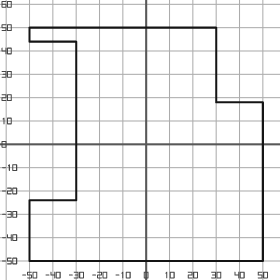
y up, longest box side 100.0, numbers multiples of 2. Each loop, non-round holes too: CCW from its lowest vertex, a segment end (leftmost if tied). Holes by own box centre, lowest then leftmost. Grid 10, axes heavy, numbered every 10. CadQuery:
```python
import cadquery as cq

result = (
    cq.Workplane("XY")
    .moveTo(-50.0, -50.0)
    .lineTo(50.0, -50.0)
    .lineTo(50.0, 18.0)
    .lineTo(30.0, 18.0)
    .lineTo(30.0, 50.0)
    .lineTo(-50.0, 50.0)
    .lineTo(-50.0, 44.0)
    .lineTo(-30.0, 44.0)
    .lineTo(-30.0, -24.0)
    .lineTo(-50.0, -24.0)
    .close()
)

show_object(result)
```